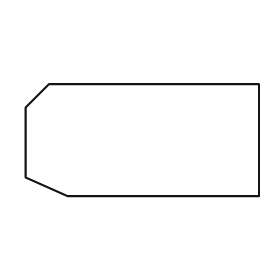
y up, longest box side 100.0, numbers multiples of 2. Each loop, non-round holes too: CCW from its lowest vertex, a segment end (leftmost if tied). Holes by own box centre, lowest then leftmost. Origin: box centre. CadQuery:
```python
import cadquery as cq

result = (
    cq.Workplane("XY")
    .moveTo(-32.0, -24.0)
    .lineTo(50.0, -24.0)
    .lineTo(50.0, 24.0)
    .lineTo(-40.0, 24.0)
    .lineTo(-50.0, 14.0)
    .lineTo(-50.0, -16.0)
    .close()
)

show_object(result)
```